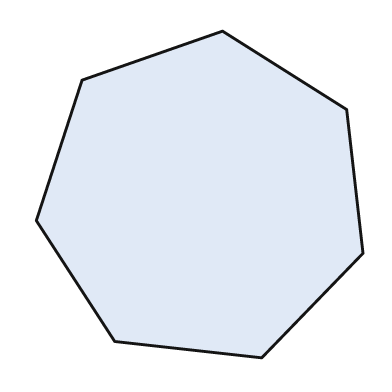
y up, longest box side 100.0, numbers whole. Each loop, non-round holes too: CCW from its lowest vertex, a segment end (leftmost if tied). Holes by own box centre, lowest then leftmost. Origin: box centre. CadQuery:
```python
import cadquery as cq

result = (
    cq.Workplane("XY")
    .moveTo(19.0, -50.0)
    .lineTo(50.0, -18.0)
    .lineTo(45.0, 26.0)
    .lineTo(7.0, 50.0)
    .lineTo(-36.0, 35.0)
    .lineTo(-50.0, -8.0)
    .lineTo(-26.0, -45.0)
    .close()
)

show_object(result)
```